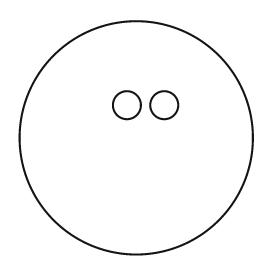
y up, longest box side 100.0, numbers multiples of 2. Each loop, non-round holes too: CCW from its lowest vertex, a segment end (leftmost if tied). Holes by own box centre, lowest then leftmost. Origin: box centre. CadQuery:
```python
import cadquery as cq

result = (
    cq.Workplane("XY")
    .moveTo(0.0, 0.0)
    .circle(50.0)
    .moveTo(-4.0, 14.0)
    .circle(6.0)
    .moveTo(12.0, 14.0)
    .circle(6.0)
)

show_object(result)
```